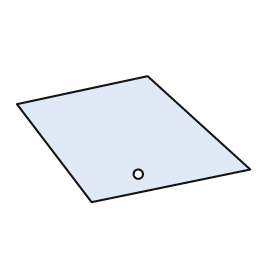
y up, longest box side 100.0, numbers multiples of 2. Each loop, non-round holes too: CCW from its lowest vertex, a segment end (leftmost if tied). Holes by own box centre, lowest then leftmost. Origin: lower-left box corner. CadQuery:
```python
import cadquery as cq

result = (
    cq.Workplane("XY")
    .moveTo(32.0, 0.0)
    .lineTo(100.0, 14.0)
    .lineTo(56.0, 54.0)
    .lineTo(0.0, 42.0)
    .close()
    .moveTo(52.0, 12.0)
    .circle(2.0)
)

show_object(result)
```